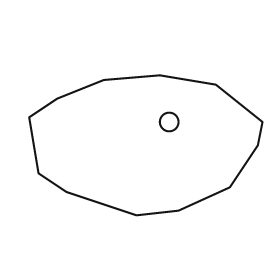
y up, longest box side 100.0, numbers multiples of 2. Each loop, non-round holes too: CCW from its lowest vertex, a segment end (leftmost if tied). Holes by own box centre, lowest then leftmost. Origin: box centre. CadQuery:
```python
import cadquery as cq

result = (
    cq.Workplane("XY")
    .moveTo(-4.0, -30.0)
    .lineTo(14.0, -28.0)
    .lineTo(36.0, -18.0)
    .lineTo(48.0, 0.0)
    .lineTo(50.0, 10.0)
    .lineTo(30.0, 26.0)
    .lineTo(6.0, 30.0)
    .lineTo(-18.0, 28.0)
    .lineTo(-38.0, 20.0)
    .lineTo(-50.0, 12.0)
    .lineTo(-46.0, -12.0)
    .lineTo(-34.0, -20.0)
    .close()
    .moveTo(10.0, 10.0)
    .circle(4.0)
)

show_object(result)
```